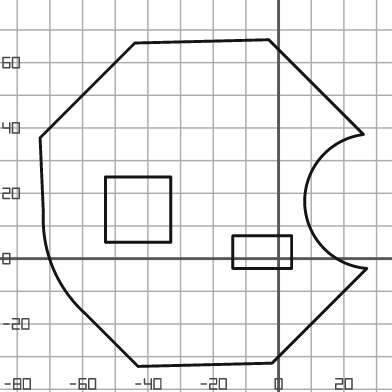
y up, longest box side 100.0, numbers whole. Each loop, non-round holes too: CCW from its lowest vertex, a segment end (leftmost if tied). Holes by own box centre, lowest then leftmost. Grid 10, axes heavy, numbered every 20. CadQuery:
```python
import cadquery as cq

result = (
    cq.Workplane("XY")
    .moveTo(-43.0, -33.0)
    .lineTo(-2.0, -32.0)
    .lineTo(27.0, -3.0)
    .threePointArc((8.0, 17.0), (26.0, 38.0))
    .lineTo(-3.0, 67.0)
    .lineTo(-44.0, 66.0)
    .lineTo(-73.0, 37.0)
    .lineTo(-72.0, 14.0)
    .threePointArc((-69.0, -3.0), (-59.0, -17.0))
    .close()
    .moveTo(-14.0, -3.0)
    .lineTo(4.0, -3.0)
    .lineTo(4.0, 7.0)
    .lineTo(-14.0, 7.0)
    .close()
    .moveTo(-53.0, 5.0)
    .lineTo(-33.0, 5.0)
    .lineTo(-33.0, 25.0)
    .lineTo(-53.0, 25.0)
    .close()
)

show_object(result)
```